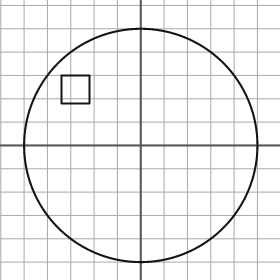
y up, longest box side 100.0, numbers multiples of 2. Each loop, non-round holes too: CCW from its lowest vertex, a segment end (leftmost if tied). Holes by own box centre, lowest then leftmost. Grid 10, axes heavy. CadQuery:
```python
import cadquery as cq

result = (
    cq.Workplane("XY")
    .moveTo(0.0, 0.0)
    .circle(50.0)
    .moveTo(-34.0, 18.0)
    .lineTo(-22.0, 18.0)
    .lineTo(-22.0, 30.0)
    .lineTo(-34.0, 30.0)
    .close()
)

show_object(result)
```